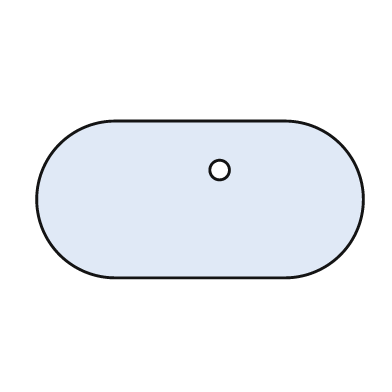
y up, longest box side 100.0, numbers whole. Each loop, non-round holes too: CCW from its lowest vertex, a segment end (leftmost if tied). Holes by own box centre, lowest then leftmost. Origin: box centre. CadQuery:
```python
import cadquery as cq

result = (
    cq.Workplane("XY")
    .moveTo(-26.0, -24.0)
    .lineTo(26.0, -24.0)
    .threePointArc((50.0, 0.0), (26.0, 24.0))
    .lineTo(-26.0, 24.0)
    .threePointArc((-50.0, 0.0), (-26.0, -24.0))
    .close()
    .moveTo(6.0, 9.0)
    .circle(3.0)
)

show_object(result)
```